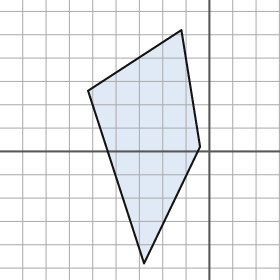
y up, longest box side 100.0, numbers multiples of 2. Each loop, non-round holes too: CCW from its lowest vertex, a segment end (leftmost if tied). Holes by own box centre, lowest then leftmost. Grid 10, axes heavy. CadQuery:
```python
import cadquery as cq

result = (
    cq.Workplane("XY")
    .moveTo(-28.0, -48.0)
    .lineTo(-4.0, 2.0)
    .lineTo(-12.0, 52.0)
    .lineTo(-52.0, 26.0)
    .close()
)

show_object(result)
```